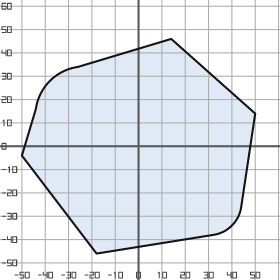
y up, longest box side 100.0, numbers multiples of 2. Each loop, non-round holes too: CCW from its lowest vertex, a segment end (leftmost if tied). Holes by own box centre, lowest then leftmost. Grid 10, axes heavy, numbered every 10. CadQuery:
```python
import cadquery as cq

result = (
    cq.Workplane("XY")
    .moveTo(-18.0, -46.0)
    .lineTo(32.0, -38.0)
    .threePointArc((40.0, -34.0), (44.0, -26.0))
    .lineTo(50.0, 14.0)
    .lineTo(14.0, 46.0)
    .lineTo(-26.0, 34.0)
    .threePointArc((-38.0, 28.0), (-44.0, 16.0))
    .lineTo(-50.0, -4.0)
    .close()
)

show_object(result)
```